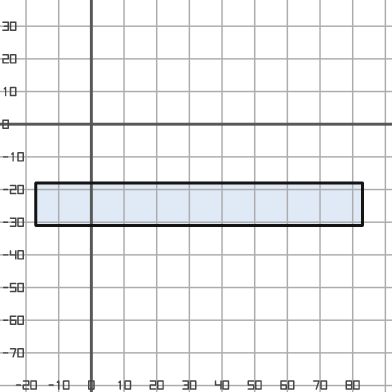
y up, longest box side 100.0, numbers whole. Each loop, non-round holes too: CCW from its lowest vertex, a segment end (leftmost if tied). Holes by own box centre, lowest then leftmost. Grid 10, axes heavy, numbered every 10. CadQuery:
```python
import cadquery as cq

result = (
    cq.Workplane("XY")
    .moveTo(-17.0, -31.0)
    .lineTo(83.0, -31.0)
    .lineTo(83.0, -18.0)
    .lineTo(-17.0, -18.0)
    .close()
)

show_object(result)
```